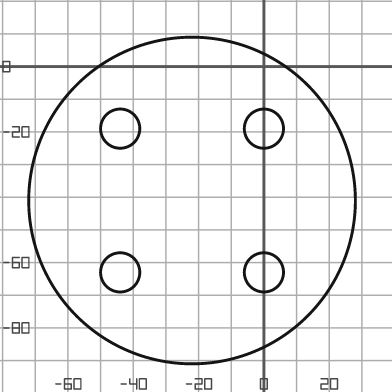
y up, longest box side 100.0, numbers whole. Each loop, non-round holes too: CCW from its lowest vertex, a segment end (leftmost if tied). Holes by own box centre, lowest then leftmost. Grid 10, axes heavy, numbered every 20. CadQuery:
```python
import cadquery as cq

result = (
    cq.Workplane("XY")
    .moveTo(-22.0, -41.0)
    .circle(50.0)
    .moveTo(-44.0, -63.0)
    .circle(6.0)
    .moveTo(0.0, -63.0)
    .circle(6.0)
    .moveTo(-44.0, -19.0)
    .circle(6.0)
    .moveTo(0.0, -19.0)
    .circle(6.0)
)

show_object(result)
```